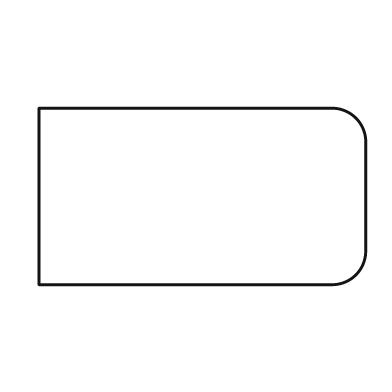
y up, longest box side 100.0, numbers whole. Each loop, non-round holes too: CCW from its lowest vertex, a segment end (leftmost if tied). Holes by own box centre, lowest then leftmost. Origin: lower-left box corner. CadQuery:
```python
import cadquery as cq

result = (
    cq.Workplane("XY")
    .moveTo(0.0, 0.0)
    .lineTo(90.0, 0.0)
    .threePointArc((97.0, 3.0), (100.0, 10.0))
    .lineTo(100.0, 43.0)
    .threePointArc((97.0, 51.0), (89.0, 54.0))
    .lineTo(0.0, 54.0)
    .close()
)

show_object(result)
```